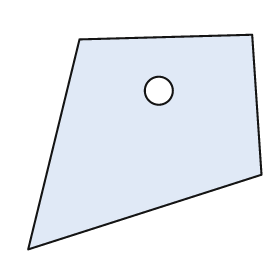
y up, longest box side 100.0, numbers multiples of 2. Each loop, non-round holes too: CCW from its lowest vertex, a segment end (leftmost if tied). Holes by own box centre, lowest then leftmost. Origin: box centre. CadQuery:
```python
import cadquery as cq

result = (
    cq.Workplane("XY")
    .moveTo(-50.0, -46.0)
    .lineTo(50.0, -14.0)
    .lineTo(46.0, 46.0)
    .lineTo(-28.0, 44.0)
    .close()
    .moveTo(6.0, 22.0)
    .circle(6.0)
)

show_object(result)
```